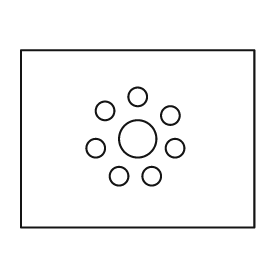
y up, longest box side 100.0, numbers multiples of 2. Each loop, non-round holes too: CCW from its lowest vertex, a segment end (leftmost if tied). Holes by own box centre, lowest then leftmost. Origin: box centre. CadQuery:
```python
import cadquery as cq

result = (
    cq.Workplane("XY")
    .moveTo(-50.0, -38.0)
    .lineTo(50.0, -38.0)
    .lineTo(50.0, 38.0)
    .lineTo(-50.0, 38.0)
    .close()
    .moveTo(-8.0, -16.0)
    .circle(4.0)
    .moveTo(6.0, -16.0)
    .circle(4.0)
    .moveTo(-18.0, -4.0)
    .circle(4.0)
    .moveTo(16.0, -4.0)
    .circle(4.0)
    .moveTo(0.0, 0.0)
    .circle(8.0)
    .moveTo(14.0, 10.0)
    .circle(4.0)
    .moveTo(-14.0, 12.0)
    .circle(4.0)
    .moveTo(0.0, 18.0)
    .circle(4.0)
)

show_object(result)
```